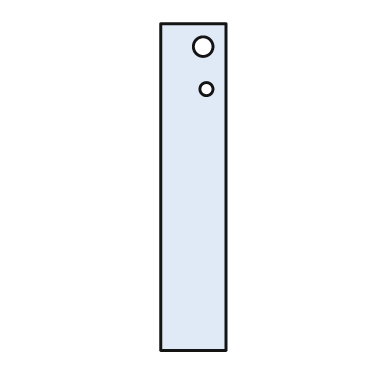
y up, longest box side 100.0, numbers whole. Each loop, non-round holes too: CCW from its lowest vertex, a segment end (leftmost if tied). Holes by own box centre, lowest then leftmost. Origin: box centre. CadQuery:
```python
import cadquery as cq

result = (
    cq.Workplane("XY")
    .moveTo(-10.0, -50.0)
    .lineTo(10.0, -50.0)
    .lineTo(10.0, 50.0)
    .lineTo(-10.0, 50.0)
    .close()
    .moveTo(4.0, 30.0)
    .circle(2.0)
    .moveTo(3.0, 43.0)
    .circle(3.0)
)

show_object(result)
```